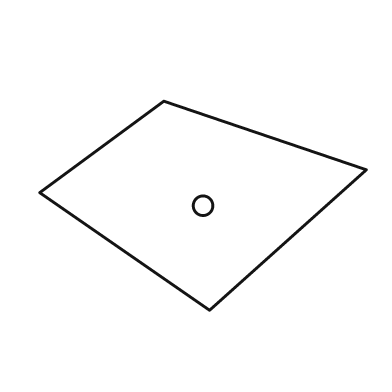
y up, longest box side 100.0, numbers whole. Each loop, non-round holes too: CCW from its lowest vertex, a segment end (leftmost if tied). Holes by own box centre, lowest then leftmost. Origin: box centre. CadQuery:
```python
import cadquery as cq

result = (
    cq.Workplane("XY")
    .moveTo(2.0, -32.0)
    .lineTo(50.0, 11.0)
    .lineTo(-12.0, 32.0)
    .lineTo(-50.0, 4.0)
    .close()
    .moveTo(0.0, 0.0)
    .circle(3.0)
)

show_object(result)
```